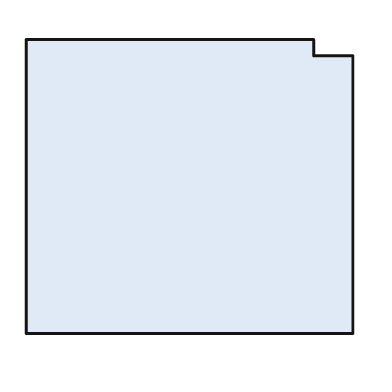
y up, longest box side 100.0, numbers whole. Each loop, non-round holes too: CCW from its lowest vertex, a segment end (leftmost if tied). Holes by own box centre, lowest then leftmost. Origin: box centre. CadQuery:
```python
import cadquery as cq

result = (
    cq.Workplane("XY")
    .moveTo(-50.0, -45.0)
    .lineTo(50.0, -45.0)
    .lineTo(50.0, 40.0)
    .lineTo(38.0, 40.0)
    .lineTo(38.0, 45.0)
    .lineTo(-50.0, 45.0)
    .close()
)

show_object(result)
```